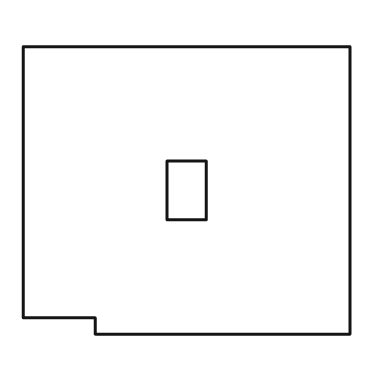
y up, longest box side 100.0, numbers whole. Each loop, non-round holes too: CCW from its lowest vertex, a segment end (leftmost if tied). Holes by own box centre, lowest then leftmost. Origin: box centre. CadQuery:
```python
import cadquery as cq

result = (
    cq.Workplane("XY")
    .moveTo(-28.0, -44.0)
    .lineTo(50.0, -44.0)
    .lineTo(50.0, 44.0)
    .lineTo(-50.0, 44.0)
    .lineTo(-50.0, -39.0)
    .lineTo(-28.0, -39.0)
    .close()
    .moveTo(-6.0, -9.0)
    .lineTo(6.0, -9.0)
    .lineTo(6.0, 9.0)
    .lineTo(-6.0, 9.0)
    .close()
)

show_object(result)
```